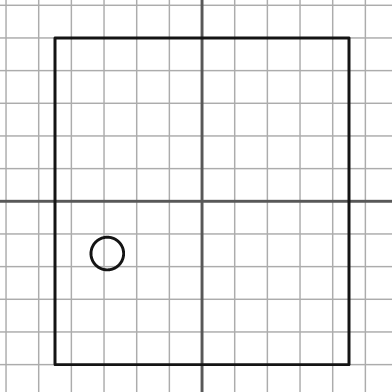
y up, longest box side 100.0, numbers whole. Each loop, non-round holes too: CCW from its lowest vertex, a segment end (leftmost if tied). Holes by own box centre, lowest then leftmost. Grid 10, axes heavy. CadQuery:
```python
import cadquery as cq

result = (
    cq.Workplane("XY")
    .moveTo(-45.0, -50.0)
    .lineTo(45.0, -50.0)
    .lineTo(45.0, 50.0)
    .lineTo(-45.0, 50.0)
    .close()
    .moveTo(-29.0, -16.0)
    .circle(5.0)
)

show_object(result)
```